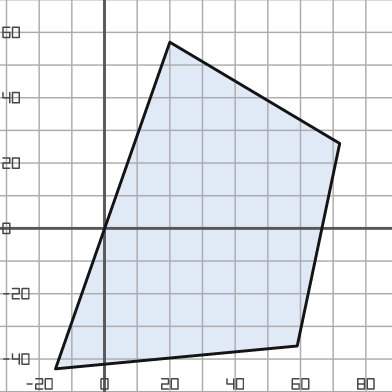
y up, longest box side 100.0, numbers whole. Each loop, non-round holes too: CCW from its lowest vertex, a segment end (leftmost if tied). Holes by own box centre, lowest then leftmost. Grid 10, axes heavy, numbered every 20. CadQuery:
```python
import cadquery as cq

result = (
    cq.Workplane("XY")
    .moveTo(-15.0, -43.0)
    .lineTo(59.0, -36.0)
    .lineTo(72.0, 26.0)
    .lineTo(20.0, 57.0)
    .close()
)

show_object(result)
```